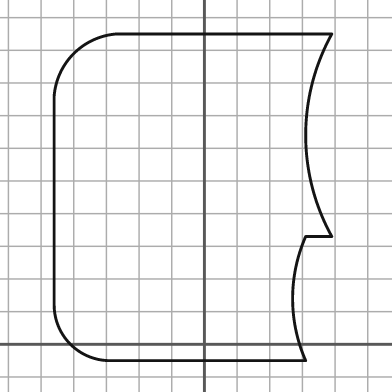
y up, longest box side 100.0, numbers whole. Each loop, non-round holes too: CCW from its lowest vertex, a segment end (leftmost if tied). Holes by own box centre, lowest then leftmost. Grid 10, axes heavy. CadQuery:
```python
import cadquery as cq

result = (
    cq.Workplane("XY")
    .moveTo(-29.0, -5.0)
    .lineTo(31.0, -5.0)
    .threePointArc((27.0, 14.0), (31.0, 33.0))
    .lineTo(39.0, 33.0)
    .threePointArc((31.0, 64.0), (39.0, 95.0))
    .lineTo(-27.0, 95.0)
    .threePointArc((-40.0, 89.0), (-46.0, 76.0))
    .lineTo(-46.0, 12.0)
    .threePointArc((-41.0, 0.0), (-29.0, -5.0))
    .close()
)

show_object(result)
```